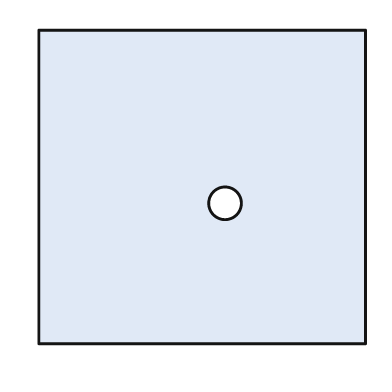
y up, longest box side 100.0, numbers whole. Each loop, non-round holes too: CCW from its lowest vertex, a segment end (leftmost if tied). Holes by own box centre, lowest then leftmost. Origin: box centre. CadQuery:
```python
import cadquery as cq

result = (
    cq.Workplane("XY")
    .moveTo(-50.0, -48.0)
    .lineTo(50.0, -48.0)
    .lineTo(50.0, 48.0)
    .lineTo(-50.0, 48.0)
    .close()
    .moveTo(7.0, -5.0)
    .circle(5.0)
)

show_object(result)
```